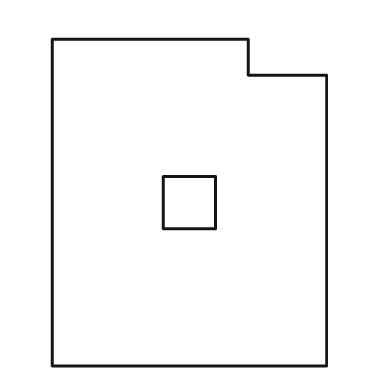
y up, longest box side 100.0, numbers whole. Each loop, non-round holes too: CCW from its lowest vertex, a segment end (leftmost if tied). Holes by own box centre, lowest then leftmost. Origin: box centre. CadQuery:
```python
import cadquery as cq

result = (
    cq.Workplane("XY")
    .moveTo(-42.0, -50.0)
    .lineTo(42.0, -50.0)
    .lineTo(42.0, 39.0)
    .lineTo(18.0, 39.0)
    .lineTo(18.0, 50.0)
    .lineTo(-42.0, 50.0)
    .close()
    .moveTo(-8.0, -8.0)
    .lineTo(8.0, -8.0)
    .lineTo(8.0, 8.0)
    .lineTo(-8.0, 8.0)
    .close()
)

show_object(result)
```